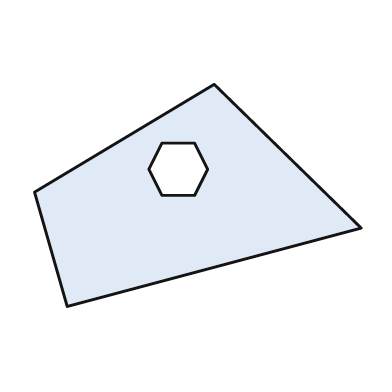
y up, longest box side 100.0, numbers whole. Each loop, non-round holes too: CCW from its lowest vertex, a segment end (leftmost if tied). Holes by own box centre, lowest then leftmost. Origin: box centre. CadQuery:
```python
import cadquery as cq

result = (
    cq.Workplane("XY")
    .moveTo(-40.0, -34.0)
    .lineTo(50.0, -10.0)
    .lineTo(5.0, 34.0)
    .lineTo(-50.0, 1.0)
    .close()
    .moveTo(-11.0, 0.0)
    .lineTo(-1.0, 0.0)
    .lineTo(3.0, 8.0)
    .lineTo(-1.0, 16.0)
    .lineTo(-11.0, 16.0)
    .lineTo(-15.0, 8.0)
    .close()
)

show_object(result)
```